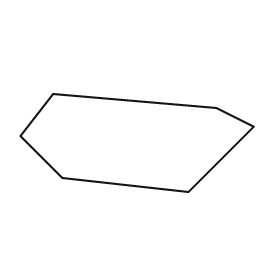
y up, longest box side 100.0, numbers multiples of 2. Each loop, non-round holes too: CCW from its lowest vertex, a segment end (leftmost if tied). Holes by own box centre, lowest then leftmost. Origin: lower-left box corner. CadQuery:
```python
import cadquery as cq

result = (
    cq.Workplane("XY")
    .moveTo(72.0, 0.0)
    .lineTo(100.0, 28.0)
    .lineTo(84.0, 36.0)
    .lineTo(14.0, 42.0)
    .lineTo(0.0, 24.0)
    .lineTo(18.0, 6.0)
    .close()
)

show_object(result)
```